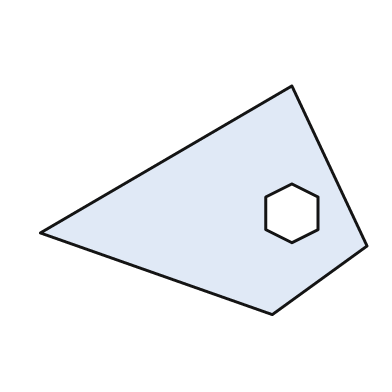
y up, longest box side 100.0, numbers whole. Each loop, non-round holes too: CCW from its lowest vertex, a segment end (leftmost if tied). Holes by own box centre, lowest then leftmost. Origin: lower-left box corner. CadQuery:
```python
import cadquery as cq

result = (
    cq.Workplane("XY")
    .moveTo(71.0, 0.0)
    .lineTo(100.0, 21.0)
    .lineTo(77.0, 70.0)
    .lineTo(0.0, 25.0)
    .close()
    .moveTo(77.0, 22.0)
    .lineTo(85.0, 26.0)
    .lineTo(85.0, 36.0)
    .lineTo(77.0, 40.0)
    .lineTo(69.0, 36.0)
    .lineTo(69.0, 26.0)
    .close()
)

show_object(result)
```